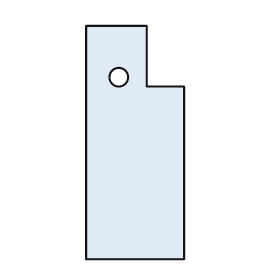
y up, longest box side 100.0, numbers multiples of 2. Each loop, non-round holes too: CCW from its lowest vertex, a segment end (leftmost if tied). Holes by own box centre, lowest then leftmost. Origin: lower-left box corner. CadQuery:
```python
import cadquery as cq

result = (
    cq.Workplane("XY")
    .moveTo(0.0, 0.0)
    .lineTo(42.0, 0.0)
    .lineTo(42.0, 74.0)
    .lineTo(26.0, 74.0)
    .lineTo(26.0, 100.0)
    .lineTo(0.0, 100.0)
    .close()
    .moveTo(14.0, 78.0)
    .circle(4.0)
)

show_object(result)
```